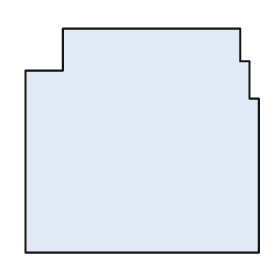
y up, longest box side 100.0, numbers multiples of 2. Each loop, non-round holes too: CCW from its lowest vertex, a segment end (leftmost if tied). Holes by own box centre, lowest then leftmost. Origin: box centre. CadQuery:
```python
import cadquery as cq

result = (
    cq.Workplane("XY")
    .moveTo(-50.0, -48.0)
    .lineTo(50.0, -48.0)
    .lineTo(50.0, 18.0)
    .lineTo(46.0, 18.0)
    .lineTo(46.0, 34.0)
    .lineTo(42.0, 34.0)
    .lineTo(42.0, 48.0)
    .lineTo(-34.0, 48.0)
    .lineTo(-34.0, 30.0)
    .lineTo(-50.0, 30.0)
    .close()
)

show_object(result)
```